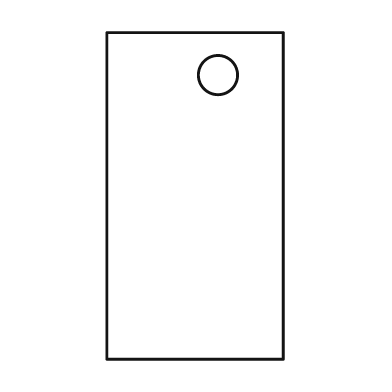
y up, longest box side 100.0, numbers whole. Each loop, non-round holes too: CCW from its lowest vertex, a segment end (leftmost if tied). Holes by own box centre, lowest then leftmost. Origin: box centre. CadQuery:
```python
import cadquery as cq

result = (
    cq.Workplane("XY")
    .moveTo(-27.0, -50.0)
    .lineTo(27.0, -50.0)
    .lineTo(27.0, 50.0)
    .lineTo(-27.0, 50.0)
    .close()
    .moveTo(7.0, 37.0)
    .circle(6.0)
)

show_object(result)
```